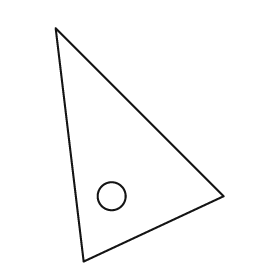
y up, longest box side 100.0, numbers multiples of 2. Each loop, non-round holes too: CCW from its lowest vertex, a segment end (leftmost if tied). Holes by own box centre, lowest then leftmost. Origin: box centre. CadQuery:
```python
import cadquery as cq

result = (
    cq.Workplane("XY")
    .moveTo(-24.0, -50.0)
    .lineTo(36.0, -22.0)
    .lineTo(-36.0, 50.0)
    .close()
    .moveTo(-12.0, -22.0)
    .circle(6.0)
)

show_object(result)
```